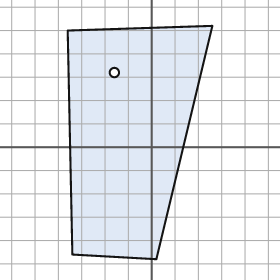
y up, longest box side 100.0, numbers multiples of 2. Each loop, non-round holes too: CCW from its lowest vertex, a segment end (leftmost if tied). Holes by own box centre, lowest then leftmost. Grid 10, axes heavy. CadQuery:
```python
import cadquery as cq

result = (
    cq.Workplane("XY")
    .moveTo(2.0, -48.0)
    .lineTo(26.0, 52.0)
    .lineTo(-36.0, 50.0)
    .lineTo(-34.0, -46.0)
    .close()
    .moveTo(-16.0, 32.0)
    .circle(2.0)
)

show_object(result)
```